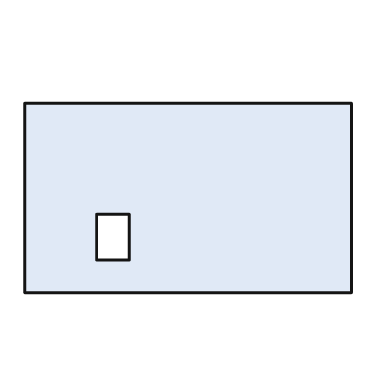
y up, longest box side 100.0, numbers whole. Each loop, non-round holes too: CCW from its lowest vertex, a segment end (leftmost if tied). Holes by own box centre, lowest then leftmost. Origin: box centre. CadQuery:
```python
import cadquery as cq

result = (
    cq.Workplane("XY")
    .moveTo(-50.0, -29.0)
    .lineTo(50.0, -29.0)
    .lineTo(50.0, 29.0)
    .lineTo(-50.0, 29.0)
    .close()
    .moveTo(-28.0, -19.0)
    .lineTo(-18.0, -19.0)
    .lineTo(-18.0, -5.0)
    .lineTo(-28.0, -5.0)
    .close()
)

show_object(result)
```